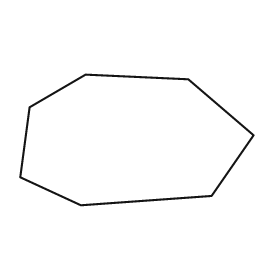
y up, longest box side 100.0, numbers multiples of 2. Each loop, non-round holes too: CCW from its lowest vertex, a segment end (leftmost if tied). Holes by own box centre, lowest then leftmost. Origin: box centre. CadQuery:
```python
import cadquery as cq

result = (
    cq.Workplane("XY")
    .moveTo(-24.0, -28.0)
    .lineTo(32.0, -24.0)
    .lineTo(50.0, 2.0)
    .lineTo(22.0, 26.0)
    .lineTo(-22.0, 28.0)
    .lineTo(-46.0, 14.0)
    .lineTo(-50.0, -16.0)
    .close()
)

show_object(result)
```